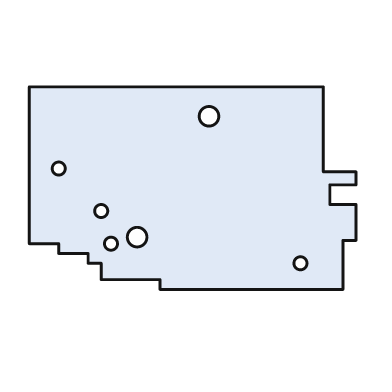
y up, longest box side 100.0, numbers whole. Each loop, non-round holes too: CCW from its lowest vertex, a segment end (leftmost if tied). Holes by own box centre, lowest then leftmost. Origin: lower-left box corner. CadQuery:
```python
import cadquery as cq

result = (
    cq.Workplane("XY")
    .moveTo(40.0, 0.0)
    .lineTo(96.0, 0.0)
    .lineTo(96.0, 15.0)
    .lineTo(100.0, 15.0)
    .lineTo(100.0, 26.0)
    .lineTo(92.0, 26.0)
    .lineTo(92.0, 32.0)
    .lineTo(100.0, 32.0)
    .lineTo(100.0, 36.0)
    .lineTo(90.0, 36.0)
    .lineTo(90.0, 62.0)
    .lineTo(0.0, 62.0)
    .lineTo(0.0, 14.0)
    .lineTo(9.0, 14.0)
    .lineTo(9.0, 11.0)
    .lineTo(18.0, 11.0)
    .lineTo(18.0, 8.0)
    .lineTo(22.0, 8.0)
    .lineTo(22.0, 3.0)
    .lineTo(40.0, 3.0)
    .close()
    .moveTo(83.0, 8.0)
    .circle(2.0)
    .moveTo(25.0, 14.0)
    .circle(2.0)
    .moveTo(33.0, 16.0)
    .circle(3.0)
    .moveTo(22.0, 24.0)
    .circle(2.0)
    .moveTo(9.0, 37.0)
    .circle(2.0)
    .moveTo(55.0, 53.0)
    .circle(3.0)
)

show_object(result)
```